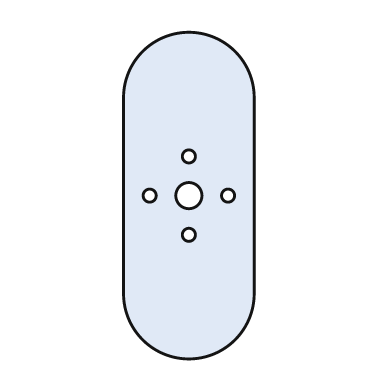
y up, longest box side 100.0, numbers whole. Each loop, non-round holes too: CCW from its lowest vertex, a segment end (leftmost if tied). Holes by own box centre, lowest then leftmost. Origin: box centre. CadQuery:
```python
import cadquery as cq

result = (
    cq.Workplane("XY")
    .moveTo(-20.0, -30.0)
    .threePointArc((0.0, -50.0), (20.0, -30.0))
    .lineTo(20.0, 30.0)
    .threePointArc((0.0, 50.0), (-20.0, 30.0))
    .close()
    .moveTo(0.0, -12.0)
    .circle(2.0)
    .moveTo(-12.0, 0.0)
    .circle(2.0)
    .moveTo(0.0, 0.0)
    .circle(4.0)
    .moveTo(12.0, 0.0)
    .circle(2.0)
    .moveTo(0.0, 12.0)
    .circle(2.0)
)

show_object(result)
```